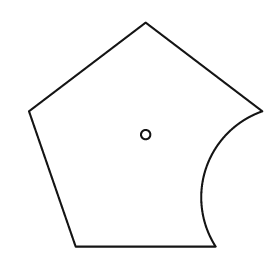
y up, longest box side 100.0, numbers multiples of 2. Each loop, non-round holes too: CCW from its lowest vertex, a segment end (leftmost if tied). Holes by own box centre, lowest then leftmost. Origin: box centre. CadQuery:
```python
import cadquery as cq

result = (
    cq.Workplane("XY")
    .moveTo(-30.0, -48.0)
    .lineTo(30.0, -48.0)
    .threePointArc((26.0, -14.0), (50.0, 10.0))
    .lineTo(0.0, 48.0)
    .lineTo(-50.0, 10.0)
    .close()
    .moveTo(0.0, 0.0)
    .circle(2.0)
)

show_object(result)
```